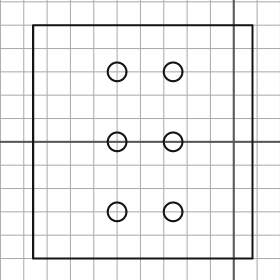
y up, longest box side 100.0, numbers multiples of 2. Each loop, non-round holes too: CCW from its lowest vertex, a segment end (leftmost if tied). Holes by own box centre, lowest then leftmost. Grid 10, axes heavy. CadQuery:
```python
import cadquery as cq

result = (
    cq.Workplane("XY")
    .moveTo(-86.0, -50.0)
    .lineTo(8.0, -50.0)
    .lineTo(8.0, 50.0)
    .lineTo(-86.0, 50.0)
    .close()
    .moveTo(-50.0, -30.0)
    .circle(4.0)
    .moveTo(-26.0, -30.0)
    .circle(4.0)
    .moveTo(-50.0, 0.0)
    .circle(4.0)
    .moveTo(-26.0, 0.0)
    .circle(4.0)
    .moveTo(-50.0, 30.0)
    .circle(4.0)
    .moveTo(-26.0, 30.0)
    .circle(4.0)
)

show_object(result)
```